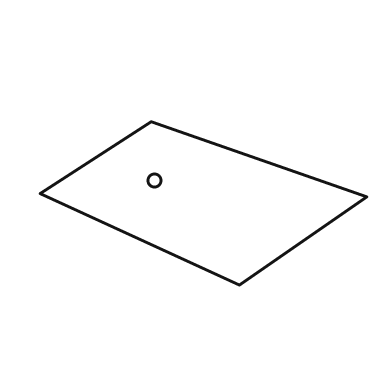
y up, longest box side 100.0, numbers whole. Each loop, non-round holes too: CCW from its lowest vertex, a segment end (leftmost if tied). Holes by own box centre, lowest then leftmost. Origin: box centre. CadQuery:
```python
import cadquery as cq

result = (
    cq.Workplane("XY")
    .moveTo(11.0, -25.0)
    .lineTo(50.0, 2.0)
    .lineTo(-16.0, 25.0)
    .lineTo(-50.0, 3.0)
    .close()
    .moveTo(-15.0, 7.0)
    .circle(2.0)
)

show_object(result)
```